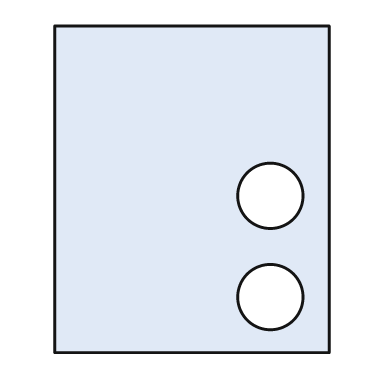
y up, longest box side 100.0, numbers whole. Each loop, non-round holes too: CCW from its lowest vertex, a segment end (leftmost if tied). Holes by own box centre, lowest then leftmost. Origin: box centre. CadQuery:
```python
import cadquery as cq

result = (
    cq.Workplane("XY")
    .moveTo(-42.0, -50.0)
    .lineTo(42.0, -50.0)
    .lineTo(42.0, 50.0)
    .lineTo(-42.0, 50.0)
    .close()
    .moveTo(24.0, -33.0)
    .circle(10.0)
    .moveTo(24.0, -2.0)
    .circle(10.0)
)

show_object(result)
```